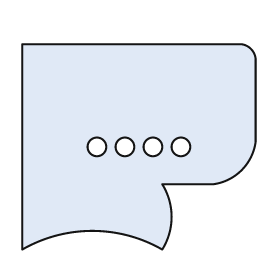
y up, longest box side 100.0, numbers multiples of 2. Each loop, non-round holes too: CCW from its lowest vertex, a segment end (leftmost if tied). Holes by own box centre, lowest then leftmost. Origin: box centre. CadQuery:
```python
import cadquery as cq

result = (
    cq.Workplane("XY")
    .moveTo(-50.0, -44.0)
    .threePointArc((-20.0, -36.0), (10.0, -44.0))
    .threePointArc((14.0, -30.0), (10.0, -16.0))
    .lineTo(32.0, -16.0)
    .threePointArc((44.0, -10.0), (50.0, 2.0))
    .lineTo(50.0, 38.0)
    .threePointArc((48.0, 42.0), (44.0, 44.0))
    .lineTo(-50.0, 44.0)
    .close()
    .moveTo(-18.0, 0.0)
    .circle(4.0)
    .moveTo(-6.0, 0.0)
    .circle(4.0)
    .moveTo(6.0, 0.0)
    .circle(4.0)
    .moveTo(18.0, 0.0)
    .circle(4.0)
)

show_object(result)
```